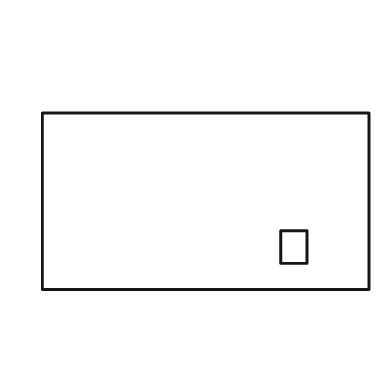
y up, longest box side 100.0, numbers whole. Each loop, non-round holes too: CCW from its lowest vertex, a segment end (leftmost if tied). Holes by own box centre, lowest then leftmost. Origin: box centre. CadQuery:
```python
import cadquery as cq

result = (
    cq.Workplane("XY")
    .moveTo(-50.0, -27.0)
    .lineTo(50.0, -27.0)
    .lineTo(50.0, 27.0)
    .lineTo(-50.0, 27.0)
    .close()
    .moveTo(23.0, -19.0)
    .lineTo(31.0, -19.0)
    .lineTo(31.0, -9.0)
    .lineTo(23.0, -9.0)
    .close()
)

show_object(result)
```